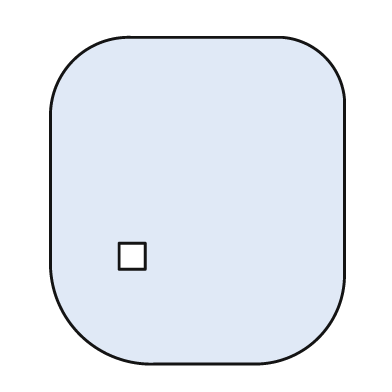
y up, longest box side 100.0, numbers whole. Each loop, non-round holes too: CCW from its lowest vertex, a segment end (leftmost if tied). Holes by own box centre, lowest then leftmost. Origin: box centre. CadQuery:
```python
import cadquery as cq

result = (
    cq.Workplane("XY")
    .moveTo(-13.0, -50.0)
    .lineTo(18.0, -50.0)
    .threePointArc((37.0, -42.0), (45.0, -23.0))
    .lineTo(45.0, 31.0)
    .threePointArc((39.0, 44.0), (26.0, 50.0))
    .lineTo(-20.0, 50.0)
    .threePointArc((-38.0, 43.0), (-45.0, 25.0))
    .lineTo(-45.0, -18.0)
    .threePointArc((-36.0, -41.0), (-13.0, -50.0))
    .close()
    .moveTo(-24.0, -21.0)
    .lineTo(-16.0, -21.0)
    .lineTo(-16.0, -13.0)
    .lineTo(-24.0, -13.0)
    .close()
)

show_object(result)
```